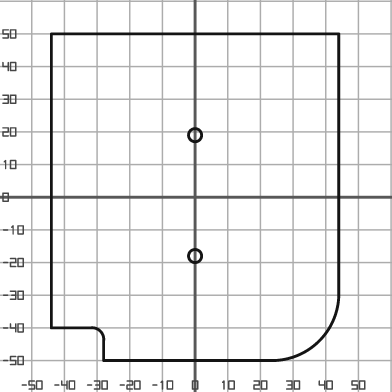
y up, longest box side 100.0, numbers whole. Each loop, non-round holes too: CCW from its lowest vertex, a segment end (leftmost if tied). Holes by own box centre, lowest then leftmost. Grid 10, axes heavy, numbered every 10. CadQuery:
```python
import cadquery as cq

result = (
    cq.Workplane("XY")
    .moveTo(-28.0, -50.0)
    .lineTo(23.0, -50.0)
    .threePointArc((38.0, -44.0), (44.0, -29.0))
    .lineTo(44.0, 50.0)
    .lineTo(-44.0, 50.0)
    .lineTo(-44.0, -40.0)
    .lineTo(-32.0, -40.0)
    .threePointArc((-29.0, -41.0), (-28.0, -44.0))
    .close()
    .moveTo(0.0, -18.0)
    .circle(2.0)
    .moveTo(0.0, 19.0)
    .circle(2.0)
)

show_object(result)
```